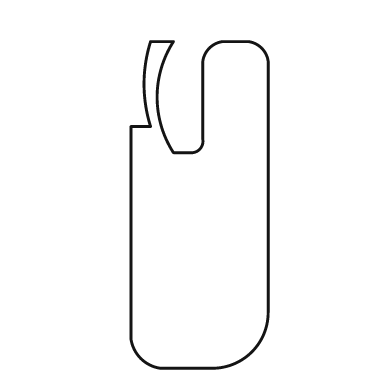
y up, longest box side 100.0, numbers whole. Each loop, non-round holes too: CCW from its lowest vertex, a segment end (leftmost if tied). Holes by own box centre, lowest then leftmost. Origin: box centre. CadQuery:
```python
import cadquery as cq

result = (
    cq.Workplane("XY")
    .moveTo(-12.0, -50.0)
    .lineTo(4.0, -50.0)
    .threePointArc((16.0, -45.0), (21.0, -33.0))
    .lineTo(21.0, 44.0)
    .threePointArc((19.0, 48.0), (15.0, 50.0))
    .lineTo(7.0, 50.0)
    .threePointArc((3.0, 48.0), (1.0, 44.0))
    .lineTo(1.0, 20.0)
    .threePointArc((0.0, 17.0), (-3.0, 16.0))
    .lineTo(-8.0, 16.0)
    .threePointArc((-13.0, 33.0), (-8.0, 50.0))
    .lineTo(-15.0, 50.0)
    .threePointArc((-17.0, 37.0), (-15.0, 24.0))
    .lineTo(-21.0, 24.0)
    .lineTo(-21.0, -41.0)
    .threePointArc((-18.0, -47.0), (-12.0, -50.0))
    .close()
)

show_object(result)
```